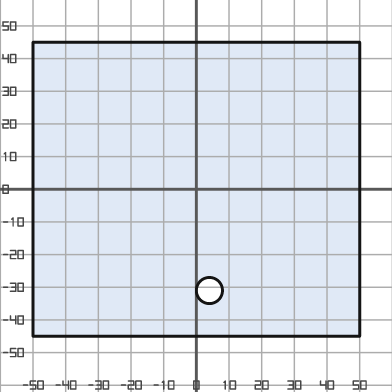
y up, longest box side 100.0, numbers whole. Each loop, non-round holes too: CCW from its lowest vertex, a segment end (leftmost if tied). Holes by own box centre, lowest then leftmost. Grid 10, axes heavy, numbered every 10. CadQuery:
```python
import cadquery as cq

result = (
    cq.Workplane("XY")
    .moveTo(-50.0, -45.0)
    .lineTo(50.0, -45.0)
    .lineTo(50.0, 45.0)
    .lineTo(-50.0, 45.0)
    .close()
    .moveTo(4.0, -31.0)
    .circle(4.0)
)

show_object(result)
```